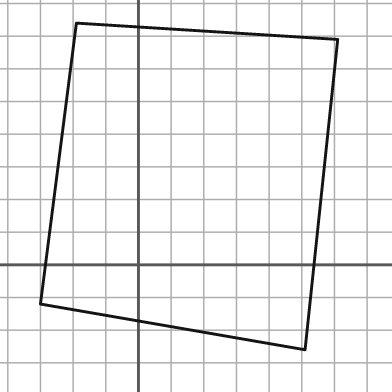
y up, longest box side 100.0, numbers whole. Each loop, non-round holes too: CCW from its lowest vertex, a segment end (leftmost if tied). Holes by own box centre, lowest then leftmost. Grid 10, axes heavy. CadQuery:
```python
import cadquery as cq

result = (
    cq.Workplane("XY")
    .moveTo(51.0, -26.0)
    .lineTo(61.0, 69.0)
    .lineTo(-19.0, 74.0)
    .lineTo(-30.0, -12.0)
    .close()
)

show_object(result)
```